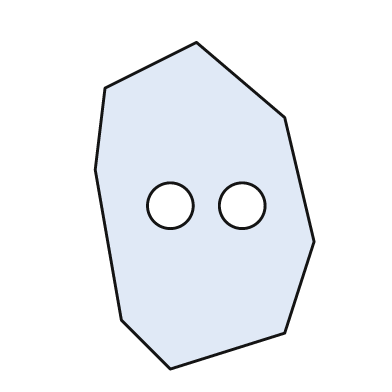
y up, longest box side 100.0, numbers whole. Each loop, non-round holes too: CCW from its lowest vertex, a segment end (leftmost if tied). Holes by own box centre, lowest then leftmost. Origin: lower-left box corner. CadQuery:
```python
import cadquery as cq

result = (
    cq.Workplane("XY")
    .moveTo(23.0, 0.0)
    .lineTo(58.0, 11.0)
    .lineTo(67.0, 39.0)
    .lineTo(58.0, 77.0)
    .lineTo(31.0, 100.0)
    .lineTo(3.0, 86.0)
    .lineTo(0.0, 61.0)
    .lineTo(8.0, 15.0)
    .close()
    .moveTo(23.0, 50.0)
    .circle(7.0)
    .moveTo(45.0, 50.0)
    .circle(7.0)
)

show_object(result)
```